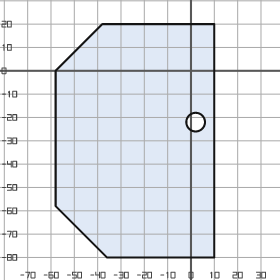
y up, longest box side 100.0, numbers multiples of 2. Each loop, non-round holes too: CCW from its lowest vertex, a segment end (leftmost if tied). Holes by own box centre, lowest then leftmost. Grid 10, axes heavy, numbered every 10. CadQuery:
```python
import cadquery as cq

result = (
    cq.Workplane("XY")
    .moveTo(-36.0, -80.0)
    .lineTo(10.0, -80.0)
    .lineTo(10.0, 20.0)
    .lineTo(-38.0, 20.0)
    .lineTo(-58.0, 0.0)
    .lineTo(-58.0, -58.0)
    .close()
    .moveTo(2.0, -22.0)
    .circle(4.0)
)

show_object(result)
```